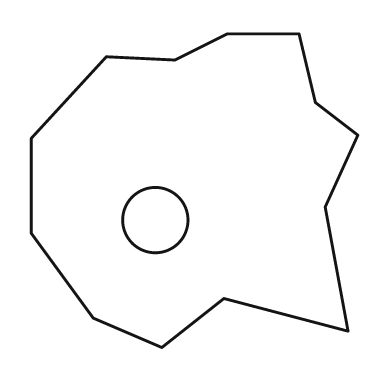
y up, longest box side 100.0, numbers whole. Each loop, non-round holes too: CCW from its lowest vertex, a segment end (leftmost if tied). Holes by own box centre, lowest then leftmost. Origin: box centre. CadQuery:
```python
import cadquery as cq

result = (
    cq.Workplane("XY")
    .moveTo(-10.0, -48.0)
    .lineTo(9.0, -33.0)
    .lineTo(47.0, -43.0)
    .lineTo(40.0, -5.0)
    .lineTo(50.0, 17.0)
    .lineTo(37.0, 27.0)
    .lineTo(32.0, 48.0)
    .lineTo(10.0, 48.0)
    .lineTo(-6.0, 40.0)
    .lineTo(-27.0, 41.0)
    .lineTo(-50.0, 16.0)
    .lineTo(-50.0, -13.0)
    .lineTo(-31.0, -39.0)
    .close()
    .moveTo(-12.0, -9.0)
    .circle(10.0)
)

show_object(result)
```